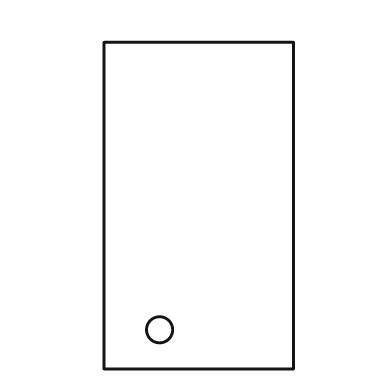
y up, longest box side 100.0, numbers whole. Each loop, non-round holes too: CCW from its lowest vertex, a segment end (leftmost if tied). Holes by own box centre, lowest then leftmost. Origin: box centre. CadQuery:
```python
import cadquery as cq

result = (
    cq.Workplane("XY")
    .moveTo(-29.0, -50.0)
    .lineTo(29.0, -50.0)
    .lineTo(29.0, 50.0)
    .lineTo(-29.0, 50.0)
    .close()
    .moveTo(-12.0, -38.0)
    .circle(4.0)
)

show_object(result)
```